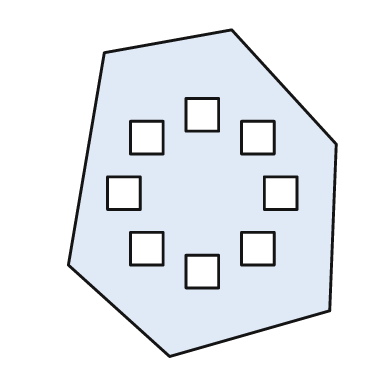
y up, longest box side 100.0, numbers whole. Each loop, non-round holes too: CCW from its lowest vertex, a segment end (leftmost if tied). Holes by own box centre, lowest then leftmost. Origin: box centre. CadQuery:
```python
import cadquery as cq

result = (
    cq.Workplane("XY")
    .moveTo(-10.0, -50.0)
    .lineTo(39.0, -36.0)
    .lineTo(41.0, 15.0)
    .lineTo(9.0, 50.0)
    .lineTo(-30.0, 43.0)
    .lineTo(-41.0, -22.0)
    .close()
    .moveTo(-5.0, -29.0)
    .lineTo(5.0, -29.0)
    .lineTo(5.0, -19.0)
    .lineTo(-5.0, -19.0)
    .close()
    .moveTo(-22.0, -22.0)
    .lineTo(-12.0, -22.0)
    .lineTo(-12.0, -12.0)
    .lineTo(-22.0, -12.0)
    .close()
    .moveTo(12.0, -22.0)
    .lineTo(22.0, -22.0)
    .lineTo(22.0, -12.0)
    .lineTo(12.0, -12.0)
    .close()
    .moveTo(-29.0, -5.0)
    .lineTo(-19.0, -5.0)
    .lineTo(-19.0, 5.0)
    .lineTo(-29.0, 5.0)
    .close()
    .moveTo(19.0, -5.0)
    .lineTo(29.0, -5.0)
    .lineTo(29.0, 5.0)
    .lineTo(19.0, 5.0)
    .close()
    .moveTo(-22.0, 12.0)
    .lineTo(-12.0, 12.0)
    .lineTo(-12.0, 22.0)
    .lineTo(-22.0, 22.0)
    .close()
    .moveTo(12.0, 12.0)
    .lineTo(22.0, 12.0)
    .lineTo(22.0, 22.0)
    .lineTo(12.0, 22.0)
    .close()
    .moveTo(-5.0, 19.0)
    .lineTo(5.0, 19.0)
    .lineTo(5.0, 29.0)
    .lineTo(-5.0, 29.0)
    .close()
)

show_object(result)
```